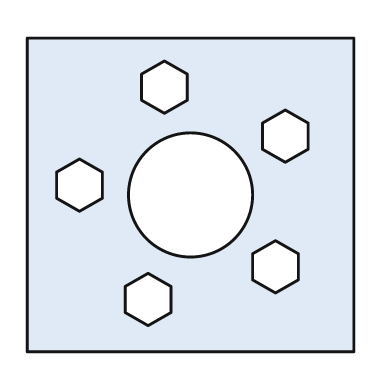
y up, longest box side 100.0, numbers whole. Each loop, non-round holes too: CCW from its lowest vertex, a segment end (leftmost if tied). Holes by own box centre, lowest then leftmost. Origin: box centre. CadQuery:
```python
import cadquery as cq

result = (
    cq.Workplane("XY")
    .moveTo(-50.0, -48.0)
    .lineTo(50.0, -48.0)
    .lineTo(50.0, 48.0)
    .lineTo(-50.0, 48.0)
    .close()
    .moveTo(-13.0, -40.0)
    .lineTo(-6.0, -36.0)
    .lineTo(-6.0, -28.0)
    .lineTo(-13.0, -24.0)
    .lineTo(-20.0, -28.0)
    .lineTo(-20.0, -36.0)
    .close()
    .moveTo(26.0, -30.0)
    .lineTo(33.0, -26.0)
    .lineTo(33.0, -18.0)
    .lineTo(26.0, -14.0)
    .lineTo(19.0, -18.0)
    .lineTo(19.0, -26.0)
    .close()
    .moveTo(0.0, 0.0)
    .circle(19.0)
    .moveTo(-34.0, -5.0)
    .lineTo(-27.0, -1.0)
    .lineTo(-27.0, 7.0)
    .lineTo(-34.0, 11.0)
    .lineTo(-41.0, 7.0)
    .lineTo(-41.0, -1.0)
    .close()
    .moveTo(29.0, 10.0)
    .lineTo(36.0, 14.0)
    .lineTo(36.0, 22.0)
    .lineTo(29.0, 26.0)
    .lineTo(22.0, 22.0)
    .lineTo(22.0, 14.0)
    .close()
    .moveTo(-8.0, 25.0)
    .lineTo(-1.0, 29.0)
    .lineTo(-1.0, 37.0)
    .lineTo(-8.0, 41.0)
    .lineTo(-15.0, 37.0)
    .lineTo(-15.0, 29.0)
    .close()
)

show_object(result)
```